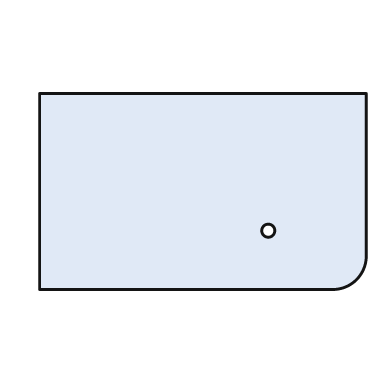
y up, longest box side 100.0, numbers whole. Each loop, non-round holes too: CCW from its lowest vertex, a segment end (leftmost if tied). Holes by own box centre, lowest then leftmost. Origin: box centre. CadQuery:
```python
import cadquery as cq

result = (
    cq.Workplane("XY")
    .moveTo(-50.0, -30.0)
    .lineTo(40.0, -30.0)
    .threePointArc((47.0, -27.0), (50.0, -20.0))
    .lineTo(50.0, 30.0)
    .lineTo(-50.0, 30.0)
    .close()
    .moveTo(20.0, -12.0)
    .circle(2.0)
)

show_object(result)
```